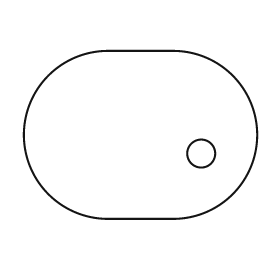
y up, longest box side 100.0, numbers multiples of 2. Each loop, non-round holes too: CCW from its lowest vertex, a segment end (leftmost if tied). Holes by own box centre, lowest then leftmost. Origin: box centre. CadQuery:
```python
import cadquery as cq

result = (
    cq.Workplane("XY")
    .moveTo(-14.0, -36.0)
    .lineTo(14.0, -36.0)
    .threePointArc((50.0, 0.0), (14.0, 36.0))
    .lineTo(-14.0, 36.0)
    .threePointArc((-50.0, 0.0), (-14.0, -36.0))
    .close()
    .moveTo(26.0, -8.0)
    .circle(6.0)
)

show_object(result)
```